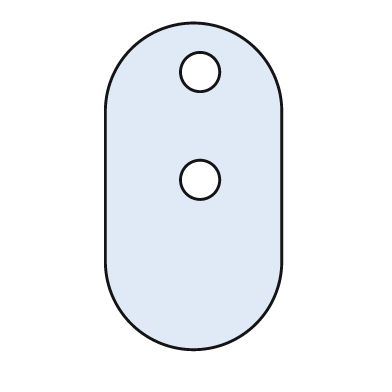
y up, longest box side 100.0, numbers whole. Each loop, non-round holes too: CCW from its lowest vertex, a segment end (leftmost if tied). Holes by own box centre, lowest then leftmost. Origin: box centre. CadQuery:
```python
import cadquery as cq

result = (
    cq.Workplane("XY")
    .moveTo(-27.0, -23.0)
    .threePointArc((0.0, -50.0), (27.0, -23.0))
    .lineTo(27.0, 23.0)
    .threePointArc((0.0, 50.0), (-27.0, 23.0))
    .close()
    .moveTo(2.0, 2.0)
    .circle(6.0)
    .moveTo(2.0, 35.0)
    .circle(6.0)
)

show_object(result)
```